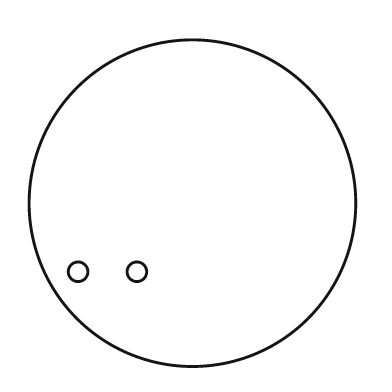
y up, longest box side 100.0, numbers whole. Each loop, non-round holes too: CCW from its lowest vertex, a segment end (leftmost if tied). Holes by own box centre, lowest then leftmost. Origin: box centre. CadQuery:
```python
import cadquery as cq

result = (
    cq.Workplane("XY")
    .moveTo(0.0, 0.0)
    .circle(50.0)
    .moveTo(-35.0, -21.0)
    .circle(3.0)
    .moveTo(-17.0, -21.0)
    .circle(3.0)
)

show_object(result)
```